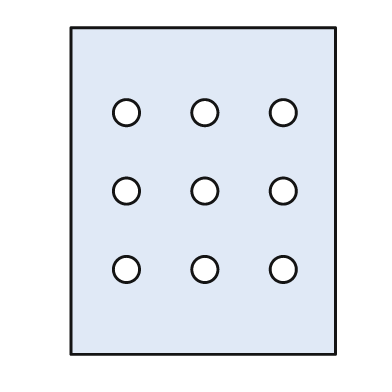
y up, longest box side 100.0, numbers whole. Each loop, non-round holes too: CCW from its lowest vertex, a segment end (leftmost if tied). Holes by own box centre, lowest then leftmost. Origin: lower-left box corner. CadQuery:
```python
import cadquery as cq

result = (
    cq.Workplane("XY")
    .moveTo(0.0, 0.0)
    .lineTo(81.0, 0.0)
    .lineTo(81.0, 100.0)
    .lineTo(0.0, 100.0)
    .close()
    .moveTo(17.0, 26.0)
    .circle(4.0)
    .moveTo(41.0, 26.0)
    .circle(4.0)
    .moveTo(65.0, 26.0)
    .circle(4.0)
    .moveTo(17.0, 50.0)
    .circle(4.0)
    .moveTo(41.0, 50.0)
    .circle(4.0)
    .moveTo(65.0, 50.0)
    .circle(4.0)
    .moveTo(17.0, 74.0)
    .circle(4.0)
    .moveTo(41.0, 74.0)
    .circle(4.0)
    .moveTo(65.0, 74.0)
    .circle(4.0)
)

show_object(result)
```